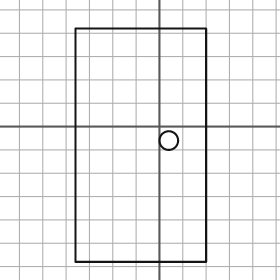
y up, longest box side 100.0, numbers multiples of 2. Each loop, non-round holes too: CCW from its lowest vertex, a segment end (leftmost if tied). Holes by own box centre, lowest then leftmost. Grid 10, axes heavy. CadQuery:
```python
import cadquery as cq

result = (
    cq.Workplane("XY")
    .moveTo(-36.0, -58.0)
    .lineTo(20.0, -58.0)
    .lineTo(20.0, 42.0)
    .lineTo(-36.0, 42.0)
    .close()
    .moveTo(4.0, -6.0)
    .circle(4.0)
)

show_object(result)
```